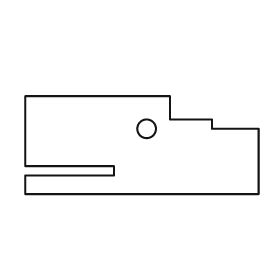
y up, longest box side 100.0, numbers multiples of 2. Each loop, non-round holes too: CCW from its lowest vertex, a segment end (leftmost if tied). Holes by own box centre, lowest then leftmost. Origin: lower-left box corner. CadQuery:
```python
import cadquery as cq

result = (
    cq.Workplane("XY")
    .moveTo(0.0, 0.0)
    .lineTo(100.0, 0.0)
    .lineTo(100.0, 28.0)
    .lineTo(80.0, 28.0)
    .lineTo(80.0, 32.0)
    .lineTo(62.0, 32.0)
    .lineTo(62.0, 42.0)
    .lineTo(0.0, 42.0)
    .lineTo(0.0, 12.0)
    .lineTo(38.0, 12.0)
    .lineTo(38.0, 8.0)
    .lineTo(0.0, 8.0)
    .close()
    .moveTo(52.0, 28.0)
    .circle(4.0)
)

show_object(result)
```